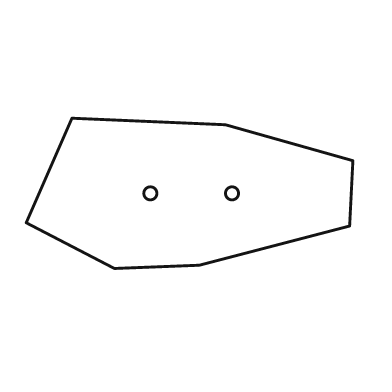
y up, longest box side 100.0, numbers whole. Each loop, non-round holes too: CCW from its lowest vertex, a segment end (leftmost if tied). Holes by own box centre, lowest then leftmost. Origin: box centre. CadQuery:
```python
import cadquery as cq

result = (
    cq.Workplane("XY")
    .moveTo(-23.0, -23.0)
    .lineTo(3.0, -22.0)
    .lineTo(49.0, -10.0)
    .lineTo(50.0, 10.0)
    .lineTo(11.0, 21.0)
    .lineTo(-36.0, 23.0)
    .lineTo(-50.0, -9.0)
    .close()
    .moveTo(-12.0, 0.0)
    .circle(2.0)
    .moveTo(13.0, 0.0)
    .circle(2.0)
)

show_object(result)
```